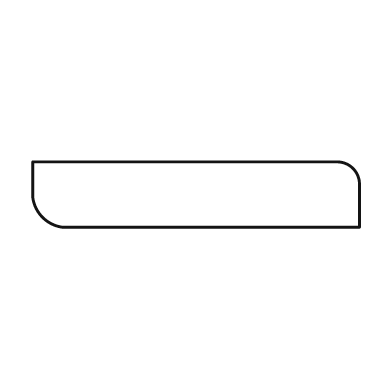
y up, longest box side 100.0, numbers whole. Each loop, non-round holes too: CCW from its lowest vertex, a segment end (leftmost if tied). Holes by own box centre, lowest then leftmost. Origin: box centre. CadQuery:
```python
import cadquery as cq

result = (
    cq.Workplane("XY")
    .moveTo(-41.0, -10.0)
    .lineTo(50.0, -10.0)
    .lineTo(50.0, 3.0)
    .threePointArc((48.0, 8.0), (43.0, 10.0))
    .lineTo(-50.0, 10.0)
    .lineTo(-50.0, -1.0)
    .threePointArc((-47.0, -7.0), (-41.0, -10.0))
    .close()
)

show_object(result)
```